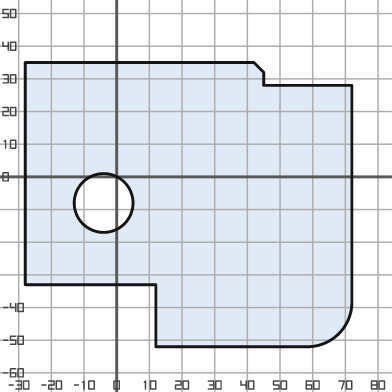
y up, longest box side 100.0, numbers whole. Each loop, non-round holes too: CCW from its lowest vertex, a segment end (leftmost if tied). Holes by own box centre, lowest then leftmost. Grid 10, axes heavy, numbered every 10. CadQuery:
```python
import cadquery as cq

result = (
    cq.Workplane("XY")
    .moveTo(12.0, -52.0)
    .lineTo(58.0, -52.0)
    .threePointArc((68.0, -48.0), (72.0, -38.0))
    .lineTo(72.0, 28.0)
    .lineTo(45.0, 28.0)
    .lineTo(45.0, 32.0)
    .lineTo(42.0, 35.0)
    .lineTo(-28.0, 35.0)
    .lineTo(-28.0, -33.0)
    .lineTo(12.0, -33.0)
    .close()
    .moveTo(-4.0, -8.0)
    .circle(9.0)
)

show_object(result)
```